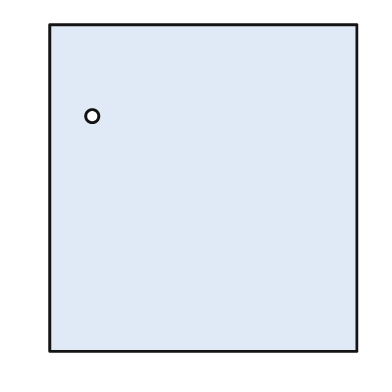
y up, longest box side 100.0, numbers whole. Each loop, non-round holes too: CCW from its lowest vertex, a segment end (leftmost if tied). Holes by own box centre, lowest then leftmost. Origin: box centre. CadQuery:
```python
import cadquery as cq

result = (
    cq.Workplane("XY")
    .moveTo(-47.0, -50.0)
    .lineTo(47.0, -50.0)
    .lineTo(47.0, 50.0)
    .lineTo(-47.0, 50.0)
    .close()
    .moveTo(-34.0, 22.0)
    .circle(2.0)
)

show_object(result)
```